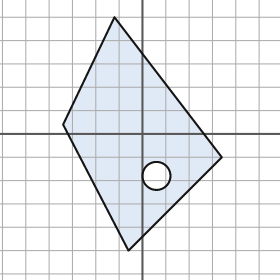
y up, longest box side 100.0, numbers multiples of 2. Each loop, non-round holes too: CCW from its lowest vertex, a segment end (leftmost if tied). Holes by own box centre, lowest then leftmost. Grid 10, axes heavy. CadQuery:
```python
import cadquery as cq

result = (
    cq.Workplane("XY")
    .moveTo(-6.0, -50.0)
    .lineTo(34.0, -10.0)
    .lineTo(-12.0, 50.0)
    .lineTo(-34.0, 4.0)
    .close()
    .moveTo(6.0, -18.0)
    .circle(6.0)
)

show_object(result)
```